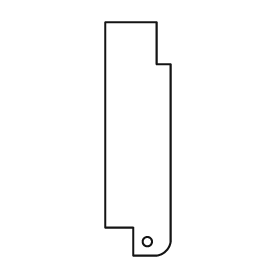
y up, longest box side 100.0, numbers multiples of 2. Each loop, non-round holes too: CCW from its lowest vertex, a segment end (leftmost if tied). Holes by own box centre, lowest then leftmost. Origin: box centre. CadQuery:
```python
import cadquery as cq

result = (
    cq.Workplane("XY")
    .moveTo(-2.0, -50.0)
    .lineTo(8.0, -50.0)
    .threePointArc((12.0, -48.0), (14.0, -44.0))
    .lineTo(14.0, 32.0)
    .lineTo(8.0, 32.0)
    .lineTo(8.0, 50.0)
    .lineTo(-14.0, 50.0)
    .lineTo(-14.0, -38.0)
    .lineTo(-2.0, -38.0)
    .close()
    .moveTo(4.0, -44.0)
    .circle(2.0)
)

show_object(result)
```